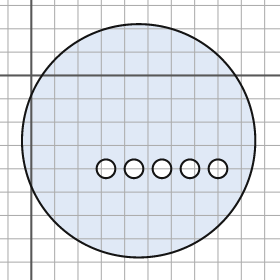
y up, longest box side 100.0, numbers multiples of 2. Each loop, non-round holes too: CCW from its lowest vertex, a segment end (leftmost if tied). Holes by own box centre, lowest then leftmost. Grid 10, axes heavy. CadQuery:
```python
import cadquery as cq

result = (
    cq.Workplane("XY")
    .moveTo(46.0, -28.0)
    .circle(50.0)
    .moveTo(32.0, -40.0)
    .circle(4.0)
    .moveTo(44.0, -40.0)
    .circle(4.0)
    .moveTo(56.0, -40.0)
    .circle(4.0)
    .moveTo(68.0, -40.0)
    .circle(4.0)
    .moveTo(80.0, -40.0)
    .circle(4.0)
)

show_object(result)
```